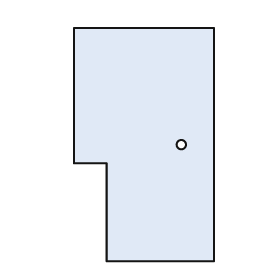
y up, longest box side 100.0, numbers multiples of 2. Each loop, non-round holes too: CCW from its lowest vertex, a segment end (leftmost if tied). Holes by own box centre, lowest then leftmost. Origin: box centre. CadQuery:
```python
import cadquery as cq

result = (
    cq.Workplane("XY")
    .moveTo(-16.0, -50.0)
    .lineTo(30.0, -50.0)
    .lineTo(30.0, 50.0)
    .lineTo(-30.0, 50.0)
    .lineTo(-30.0, -8.0)
    .lineTo(-16.0, -8.0)
    .close()
    .moveTo(16.0, 0.0)
    .circle(2.0)
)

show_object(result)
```